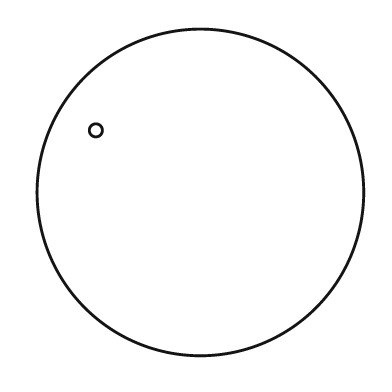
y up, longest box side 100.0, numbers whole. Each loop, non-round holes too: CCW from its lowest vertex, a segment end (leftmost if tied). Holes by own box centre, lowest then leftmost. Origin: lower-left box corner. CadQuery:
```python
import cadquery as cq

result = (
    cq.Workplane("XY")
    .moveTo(50.0, 50.0)
    .circle(50.0)
    .moveTo(18.0, 69.0)
    .circle(2.0)
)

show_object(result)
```